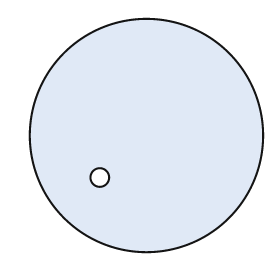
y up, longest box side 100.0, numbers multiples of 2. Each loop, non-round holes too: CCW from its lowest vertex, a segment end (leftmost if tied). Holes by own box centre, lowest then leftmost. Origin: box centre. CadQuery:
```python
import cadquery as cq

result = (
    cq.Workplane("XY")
    .moveTo(0.0, 0.0)
    .circle(50.0)
    .moveTo(-20.0, -18.0)
    .circle(4.0)
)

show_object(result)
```